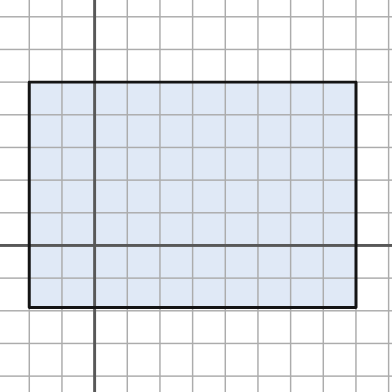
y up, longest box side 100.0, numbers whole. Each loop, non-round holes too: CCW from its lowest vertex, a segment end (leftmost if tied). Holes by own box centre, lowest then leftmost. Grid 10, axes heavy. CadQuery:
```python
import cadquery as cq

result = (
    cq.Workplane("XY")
    .moveTo(-20.0, -19.0)
    .lineTo(80.0, -19.0)
    .lineTo(80.0, 50.0)
    .lineTo(-20.0, 50.0)
    .close()
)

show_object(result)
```